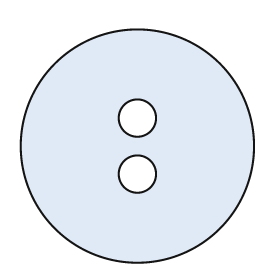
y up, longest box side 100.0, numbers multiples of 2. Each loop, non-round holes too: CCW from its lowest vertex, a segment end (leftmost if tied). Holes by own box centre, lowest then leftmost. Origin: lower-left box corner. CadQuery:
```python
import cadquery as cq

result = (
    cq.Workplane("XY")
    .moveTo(50.0, 50.0)
    .circle(50.0)
    .moveTo(50.0, 38.0)
    .circle(8.0)
    .moveTo(50.0, 62.0)
    .circle(8.0)
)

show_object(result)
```